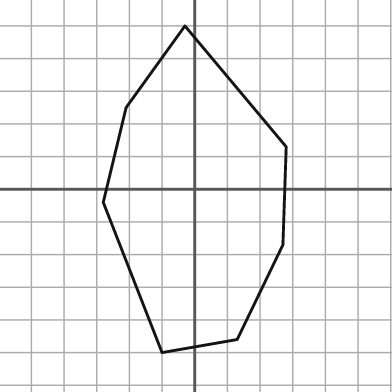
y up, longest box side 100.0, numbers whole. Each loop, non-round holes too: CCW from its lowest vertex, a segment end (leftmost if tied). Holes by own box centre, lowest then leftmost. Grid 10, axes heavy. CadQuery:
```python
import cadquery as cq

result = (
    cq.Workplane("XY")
    .moveTo(-10.0, -50.0)
    .lineTo(13.0, -46.0)
    .lineTo(27.0, -17.0)
    .lineTo(28.0, 13.0)
    .lineTo(-3.0, 50.0)
    .lineTo(-21.0, 25.0)
    .lineTo(-28.0, -4.0)
    .close()
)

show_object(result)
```